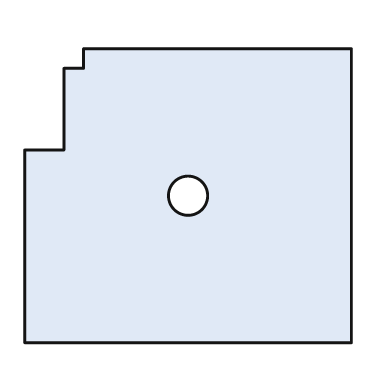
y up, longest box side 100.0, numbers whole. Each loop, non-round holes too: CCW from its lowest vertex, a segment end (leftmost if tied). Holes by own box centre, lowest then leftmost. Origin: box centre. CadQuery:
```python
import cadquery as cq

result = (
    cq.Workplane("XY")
    .moveTo(-50.0, -45.0)
    .lineTo(50.0, -45.0)
    .lineTo(50.0, 45.0)
    .lineTo(-32.0, 45.0)
    .lineTo(-32.0, 39.0)
    .lineTo(-38.0, 39.0)
    .lineTo(-38.0, 14.0)
    .lineTo(-50.0, 14.0)
    .close()
    .moveTo(0.0, 0.0)
    .circle(6.0)
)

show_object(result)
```